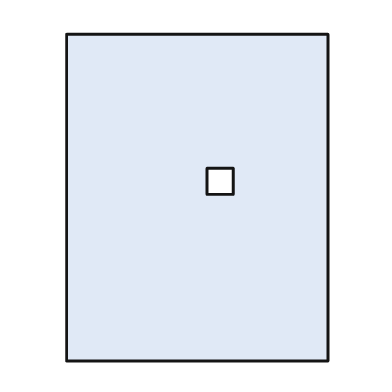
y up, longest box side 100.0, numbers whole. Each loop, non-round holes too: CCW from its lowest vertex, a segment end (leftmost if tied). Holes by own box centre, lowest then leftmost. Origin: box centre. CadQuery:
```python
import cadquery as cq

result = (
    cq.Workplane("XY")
    .moveTo(-40.0, -50.0)
    .lineTo(40.0, -50.0)
    .lineTo(40.0, 50.0)
    .lineTo(-40.0, 50.0)
    .close()
    .moveTo(3.0, 1.0)
    .lineTo(11.0, 1.0)
    .lineTo(11.0, 9.0)
    .lineTo(3.0, 9.0)
    .close()
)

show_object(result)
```